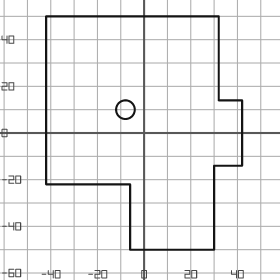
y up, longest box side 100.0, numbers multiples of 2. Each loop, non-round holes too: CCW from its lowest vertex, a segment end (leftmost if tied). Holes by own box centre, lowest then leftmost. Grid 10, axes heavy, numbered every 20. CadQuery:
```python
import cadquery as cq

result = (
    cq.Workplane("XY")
    .moveTo(-6.0, -50.0)
    .lineTo(30.0, -50.0)
    .lineTo(30.0, -14.0)
    .lineTo(42.0, -14.0)
    .lineTo(42.0, 14.0)
    .lineTo(32.0, 14.0)
    .lineTo(32.0, 50.0)
    .lineTo(-42.0, 50.0)
    .lineTo(-42.0, -22.0)
    .lineTo(-6.0, -22.0)
    .close()
    .moveTo(-8.0, 10.0)
    .circle(4.0)
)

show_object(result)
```